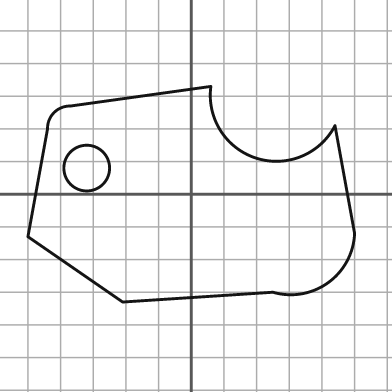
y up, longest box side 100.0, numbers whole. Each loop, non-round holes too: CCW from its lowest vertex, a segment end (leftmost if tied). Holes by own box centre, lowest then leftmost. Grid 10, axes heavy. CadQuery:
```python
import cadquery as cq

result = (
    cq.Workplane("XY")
    .moveTo(-21.0, -33.0)
    .lineTo(25.0, -30.0)
    .threePointArc((42.0, -27.0), (50.0, -12.0))
    .lineTo(44.0, 21.0)
    .threePointArc((20.0, 11.0), (6.0, 33.0))
    .lineTo(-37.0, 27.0)
    .threePointArc((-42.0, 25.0), (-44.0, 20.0))
    .lineTo(-50.0, -13.0)
    .close()
    .moveTo(-32.0, 8.0)
    .circle(7.0)
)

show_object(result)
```